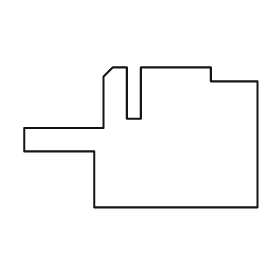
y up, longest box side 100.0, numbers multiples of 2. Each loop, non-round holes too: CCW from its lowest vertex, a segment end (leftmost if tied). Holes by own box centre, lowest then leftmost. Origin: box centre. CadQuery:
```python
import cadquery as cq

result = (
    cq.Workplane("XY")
    .moveTo(-20.0, -30.0)
    .lineTo(50.0, -30.0)
    .lineTo(50.0, 24.0)
    .lineTo(30.0, 24.0)
    .lineTo(30.0, 30.0)
    .lineTo(0.0, 30.0)
    .lineTo(0.0, 8.0)
    .lineTo(-6.0, 8.0)
    .lineTo(-6.0, 30.0)
    .lineTo(-12.0, 30.0)
    .lineTo(-16.0, 26.0)
    .lineTo(-16.0, 4.0)
    .lineTo(-50.0, 4.0)
    .lineTo(-50.0, -6.0)
    .lineTo(-20.0, -6.0)
    .close()
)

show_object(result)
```